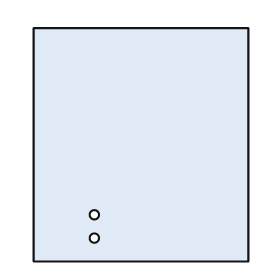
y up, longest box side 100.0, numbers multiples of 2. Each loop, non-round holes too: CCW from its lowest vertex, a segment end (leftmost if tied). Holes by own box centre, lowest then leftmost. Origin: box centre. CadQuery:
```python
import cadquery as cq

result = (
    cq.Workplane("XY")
    .moveTo(-46.0, -50.0)
    .lineTo(46.0, -50.0)
    .lineTo(46.0, 50.0)
    .lineTo(-46.0, 50.0)
    .close()
    .moveTo(-20.0, -40.0)
    .circle(2.0)
    .moveTo(-20.0, -30.0)
    .circle(2.0)
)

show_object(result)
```